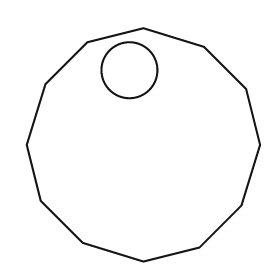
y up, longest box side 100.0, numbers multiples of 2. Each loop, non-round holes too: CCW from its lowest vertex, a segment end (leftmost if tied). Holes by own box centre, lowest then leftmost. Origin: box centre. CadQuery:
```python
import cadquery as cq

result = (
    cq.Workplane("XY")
    .moveTo(0.0, -50.0)
    .lineTo(24.0, -44.0)
    .lineTo(42.0, -26.0)
    .lineTo(50.0, 0.0)
    .lineTo(44.0, 24.0)
    .lineTo(26.0, 42.0)
    .lineTo(0.0, 50.0)
    .lineTo(-24.0, 44.0)
    .lineTo(-42.0, 26.0)
    .lineTo(-50.0, 0.0)
    .lineTo(-44.0, -24.0)
    .lineTo(-26.0, -42.0)
    .close()
    .moveTo(-6.0, 32.0)
    .circle(12.0)
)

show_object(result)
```